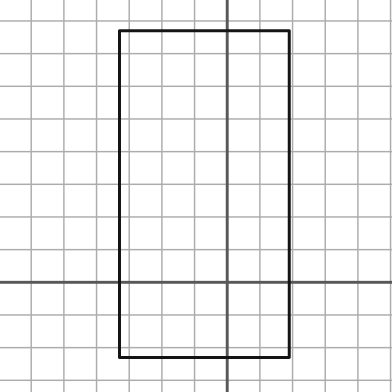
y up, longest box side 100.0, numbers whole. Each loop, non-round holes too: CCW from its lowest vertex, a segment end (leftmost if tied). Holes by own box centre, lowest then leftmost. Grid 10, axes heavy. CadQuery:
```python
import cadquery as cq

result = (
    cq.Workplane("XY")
    .moveTo(-33.0, -23.0)
    .lineTo(19.0, -23.0)
    .lineTo(19.0, 77.0)
    .lineTo(-33.0, 77.0)
    .close()
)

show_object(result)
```